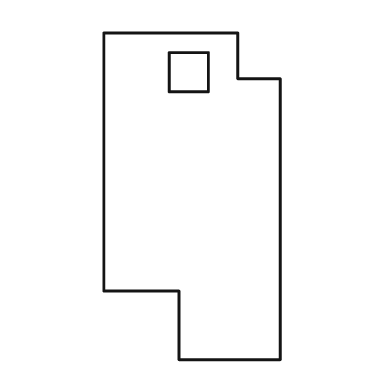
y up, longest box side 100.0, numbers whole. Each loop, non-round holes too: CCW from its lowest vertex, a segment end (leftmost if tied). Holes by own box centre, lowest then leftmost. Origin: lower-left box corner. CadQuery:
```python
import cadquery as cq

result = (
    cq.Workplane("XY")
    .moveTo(23.0, 0.0)
    .lineTo(54.0, 0.0)
    .lineTo(54.0, 86.0)
    .lineTo(41.0, 86.0)
    .lineTo(41.0, 100.0)
    .lineTo(0.0, 100.0)
    .lineTo(0.0, 21.0)
    .lineTo(23.0, 21.0)
    .close()
    .moveTo(20.0, 82.0)
    .lineTo(32.0, 82.0)
    .lineTo(32.0, 94.0)
    .lineTo(20.0, 94.0)
    .close()
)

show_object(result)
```